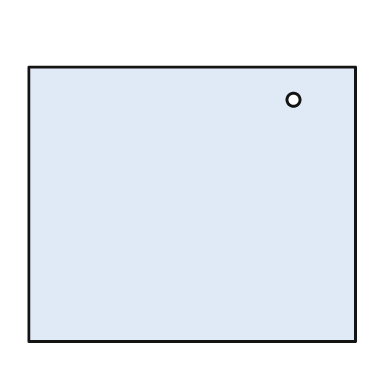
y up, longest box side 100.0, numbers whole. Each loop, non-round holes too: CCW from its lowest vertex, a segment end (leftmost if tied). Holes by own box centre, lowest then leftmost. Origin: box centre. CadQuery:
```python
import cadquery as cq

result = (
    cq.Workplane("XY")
    .moveTo(-50.0, -42.0)
    .lineTo(50.0, -42.0)
    .lineTo(50.0, 42.0)
    .lineTo(-50.0, 42.0)
    .close()
    .moveTo(31.0, 32.0)
    .circle(2.0)
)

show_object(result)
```